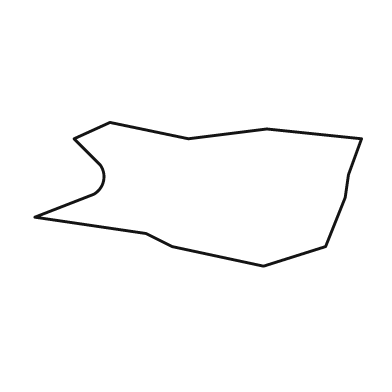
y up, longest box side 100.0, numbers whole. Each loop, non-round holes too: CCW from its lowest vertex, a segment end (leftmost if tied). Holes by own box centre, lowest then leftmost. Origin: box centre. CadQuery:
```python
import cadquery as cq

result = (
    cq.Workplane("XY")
    .moveTo(20.0, -22.0)
    .lineTo(39.0, -16.0)
    .lineTo(45.0, -1.0)
    .lineTo(46.0, 6.0)
    .lineTo(50.0, 17.0)
    .lineTo(21.0, 20.0)
    .lineTo(-3.0, 17.0)
    .lineTo(-27.0, 22.0)
    .lineTo(-38.0, 17.0)
    .lineTo(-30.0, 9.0)
    .threePointArc((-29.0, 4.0), (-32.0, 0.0))
    .lineTo(-50.0, -7.0)
    .lineTo(-16.0, -12.0)
    .lineTo(-8.0, -16.0)
    .close()
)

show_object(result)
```